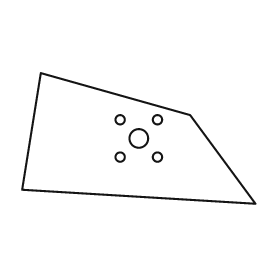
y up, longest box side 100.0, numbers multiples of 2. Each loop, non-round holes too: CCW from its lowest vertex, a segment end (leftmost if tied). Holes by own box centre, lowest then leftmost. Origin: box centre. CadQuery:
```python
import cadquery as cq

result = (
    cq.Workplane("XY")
    .moveTo(50.0, -28.0)
    .lineTo(22.0, 10.0)
    .lineTo(-42.0, 28.0)
    .lineTo(-50.0, -22.0)
    .close()
    .moveTo(-8.0, -8.0)
    .circle(2.0)
    .moveTo(8.0, -8.0)
    .circle(2.0)
    .moveTo(0.0, 0.0)
    .circle(4.0)
    .moveTo(-8.0, 8.0)
    .circle(2.0)
    .moveTo(8.0, 8.0)
    .circle(2.0)
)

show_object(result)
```